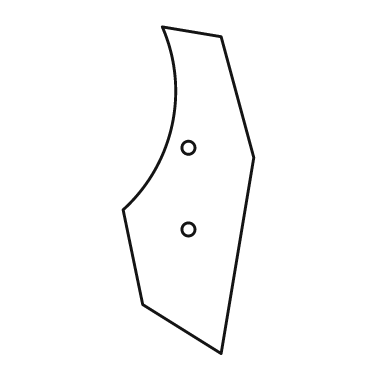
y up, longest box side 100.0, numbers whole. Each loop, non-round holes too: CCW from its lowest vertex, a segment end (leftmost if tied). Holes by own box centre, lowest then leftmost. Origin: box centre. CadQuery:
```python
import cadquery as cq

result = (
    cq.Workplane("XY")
    .moveTo(10.0, -50.0)
    .lineTo(20.0, 10.0)
    .lineTo(10.0, 47.0)
    .lineTo(-8.0, 50.0)
    .threePointArc((-5.0, 20.0), (-20.0, -6.0))
    .lineTo(-14.0, -35.0)
    .close()
    .moveTo(0.0, -12.0)
    .circle(2.0)
    .moveTo(0.0, 13.0)
    .circle(2.0)
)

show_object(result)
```